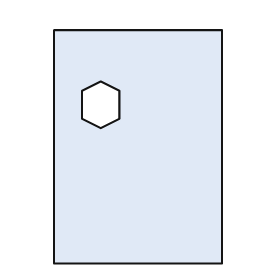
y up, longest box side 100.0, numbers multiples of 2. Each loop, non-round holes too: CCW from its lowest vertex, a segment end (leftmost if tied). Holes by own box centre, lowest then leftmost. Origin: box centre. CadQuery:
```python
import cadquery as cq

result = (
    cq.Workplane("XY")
    .moveTo(-36.0, -50.0)
    .lineTo(36.0, -50.0)
    .lineTo(36.0, 50.0)
    .lineTo(-36.0, 50.0)
    .close()
    .moveTo(-16.0, 8.0)
    .lineTo(-8.0, 12.0)
    .lineTo(-8.0, 24.0)
    .lineTo(-16.0, 28.0)
    .lineTo(-24.0, 24.0)
    .lineTo(-24.0, 12.0)
    .close()
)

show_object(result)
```